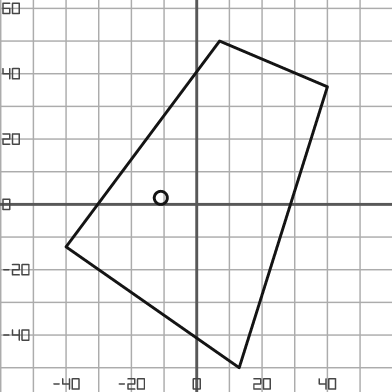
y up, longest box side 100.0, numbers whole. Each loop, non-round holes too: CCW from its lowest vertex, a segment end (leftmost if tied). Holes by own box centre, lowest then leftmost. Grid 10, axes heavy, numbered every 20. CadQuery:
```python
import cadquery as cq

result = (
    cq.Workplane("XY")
    .moveTo(13.0, -50.0)
    .lineTo(40.0, 36.0)
    .lineTo(7.0, 50.0)
    .lineTo(-40.0, -13.0)
    .close()
    .moveTo(-11.0, 2.0)
    .circle(2.0)
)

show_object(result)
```